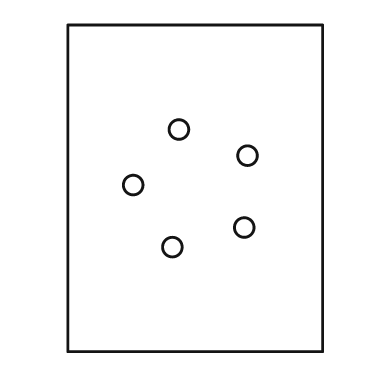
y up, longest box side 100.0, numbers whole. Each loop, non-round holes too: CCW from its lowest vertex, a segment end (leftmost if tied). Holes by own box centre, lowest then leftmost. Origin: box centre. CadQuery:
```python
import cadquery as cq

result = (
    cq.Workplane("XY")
    .moveTo(-39.0, -50.0)
    .lineTo(39.0, -50.0)
    .lineTo(39.0, 50.0)
    .lineTo(-39.0, 50.0)
    .close()
    .moveTo(-7.0, -18.0)
    .circle(3.0)
    .moveTo(15.0, -12.0)
    .circle(3.0)
    .moveTo(-19.0, 1.0)
    .circle(3.0)
    .moveTo(16.0, 10.0)
    .circle(3.0)
    .moveTo(-5.0, 18.0)
    .circle(3.0)
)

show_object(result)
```